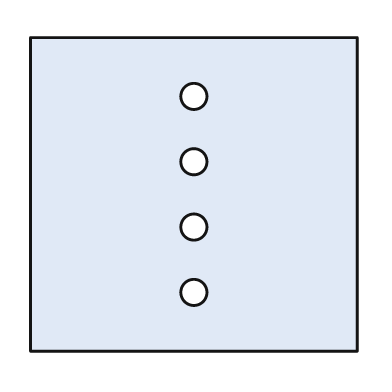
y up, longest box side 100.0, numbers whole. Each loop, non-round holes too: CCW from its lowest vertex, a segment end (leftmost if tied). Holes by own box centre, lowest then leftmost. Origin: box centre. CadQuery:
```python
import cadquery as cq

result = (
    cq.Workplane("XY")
    .moveTo(-50.0, -48.0)
    .lineTo(50.0, -48.0)
    .lineTo(50.0, 48.0)
    .lineTo(-50.0, 48.0)
    .close()
    .moveTo(0.0, -30.0)
    .circle(4.0)
    .moveTo(0.0, -10.0)
    .circle(4.0)
    .moveTo(0.0, 10.0)
    .circle(4.0)
    .moveTo(0.0, 30.0)
    .circle(4.0)
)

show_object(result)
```